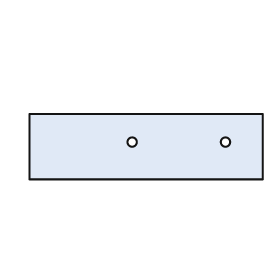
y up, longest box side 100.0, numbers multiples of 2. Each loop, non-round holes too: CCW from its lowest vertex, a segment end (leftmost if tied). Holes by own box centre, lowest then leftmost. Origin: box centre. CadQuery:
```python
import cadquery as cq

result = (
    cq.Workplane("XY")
    .moveTo(-50.0, -14.0)
    .lineTo(50.0, -14.0)
    .lineTo(50.0, 14.0)
    .lineTo(-50.0, 14.0)
    .close()
    .moveTo(-6.0, 2.0)
    .circle(2.0)
    .moveTo(34.0, 2.0)
    .circle(2.0)
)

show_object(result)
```